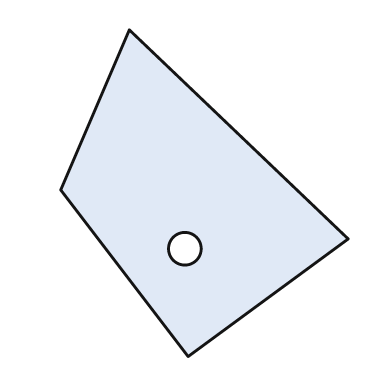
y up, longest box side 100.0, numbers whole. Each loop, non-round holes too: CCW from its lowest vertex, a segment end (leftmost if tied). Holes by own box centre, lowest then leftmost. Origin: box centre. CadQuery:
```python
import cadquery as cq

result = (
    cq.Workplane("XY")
    .moveTo(-5.0, -50.0)
    .lineTo(44.0, -14.0)
    .lineTo(-23.0, 50.0)
    .lineTo(-44.0, 1.0)
    .close()
    .moveTo(-6.0, -17.0)
    .circle(5.0)
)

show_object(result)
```